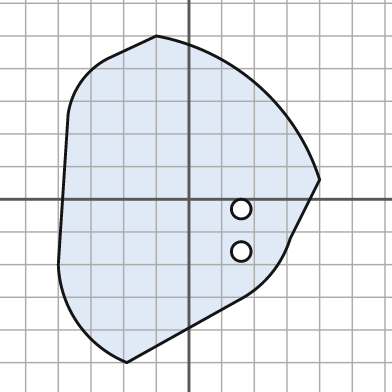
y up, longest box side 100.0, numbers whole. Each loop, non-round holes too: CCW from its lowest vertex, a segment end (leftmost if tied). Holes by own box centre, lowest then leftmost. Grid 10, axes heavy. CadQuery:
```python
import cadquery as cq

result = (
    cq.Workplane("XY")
    .moveTo(-19.0, -50.0)
    .lineTo(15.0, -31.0)
    .threePointArc((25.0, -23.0), (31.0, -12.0))
    .lineTo(40.0, 6.0)
    .threePointArc((21.0, 35.0), (-10.0, 50.0))
    .lineTo(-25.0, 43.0)
    .threePointArc((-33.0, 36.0), (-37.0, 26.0))
    .lineTo(-40.0, -20.0)
    .threePointArc((-34.0, -38.0), (-19.0, -50.0))
    .close()
    .moveTo(16.0, -16.0)
    .circle(3.0)
    .moveTo(16.0, -3.0)
    .circle(3.0)
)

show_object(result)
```